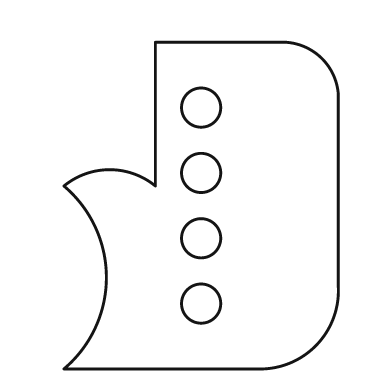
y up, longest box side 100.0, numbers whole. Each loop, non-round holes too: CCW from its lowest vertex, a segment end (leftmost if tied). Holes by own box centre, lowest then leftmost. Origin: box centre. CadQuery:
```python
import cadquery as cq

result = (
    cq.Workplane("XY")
    .moveTo(-42.0, -50.0)
    .lineTo(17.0, -50.0)
    .threePointArc((35.0, -43.0), (42.0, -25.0))
    .lineTo(42.0, 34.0)
    .threePointArc((37.0, 45.0), (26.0, 50.0))
    .lineTo(-14.0, 50.0)
    .lineTo(-14.0, 6.0)
    .threePointArc((-28.0, 11.0), (-42.0, 6.0))
    .threePointArc((-29.0, -22.0), (-42.0, -50.0))
    .close()
    .moveTo(0.0, -30.0)
    .circle(6.0)
    .moveTo(0.0, -10.0)
    .circle(6.0)
    .moveTo(0.0, 10.0)
    .circle(6.0)
    .moveTo(0.0, 30.0)
    .circle(6.0)
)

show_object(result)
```